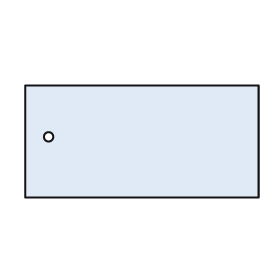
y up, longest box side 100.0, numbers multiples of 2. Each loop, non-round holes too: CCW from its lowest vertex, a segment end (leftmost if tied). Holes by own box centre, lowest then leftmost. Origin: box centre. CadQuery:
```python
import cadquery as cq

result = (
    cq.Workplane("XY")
    .moveTo(-50.0, -24.0)
    .lineTo(50.0, -24.0)
    .lineTo(50.0, 24.0)
    .lineTo(-50.0, 24.0)
    .close()
    .moveTo(-40.0, 2.0)
    .circle(2.0)
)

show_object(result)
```